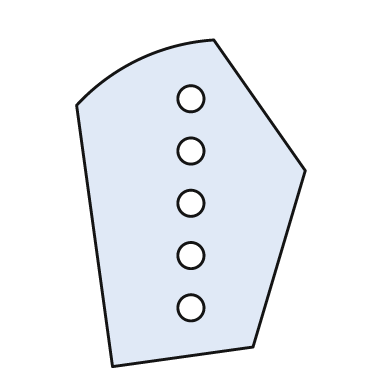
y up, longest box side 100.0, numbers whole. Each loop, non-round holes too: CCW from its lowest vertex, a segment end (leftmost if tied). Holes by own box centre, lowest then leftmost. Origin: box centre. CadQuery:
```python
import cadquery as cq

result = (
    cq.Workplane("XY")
    .moveTo(-24.0, -50.0)
    .lineTo(19.0, -44.0)
    .lineTo(35.0, 10.0)
    .lineTo(7.0, 50.0)
    .threePointArc((-16.0, 44.0), (-35.0, 30.0))
    .close()
    .moveTo(0.0, -32.0)
    .circle(4.0)
    .moveTo(0.0, -16.0)
    .circle(4.0)
    .moveTo(0.0, 0.0)
    .circle(4.0)
    .moveTo(0.0, 16.0)
    .circle(4.0)
    .moveTo(0.0, 32.0)
    .circle(4.0)
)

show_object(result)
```